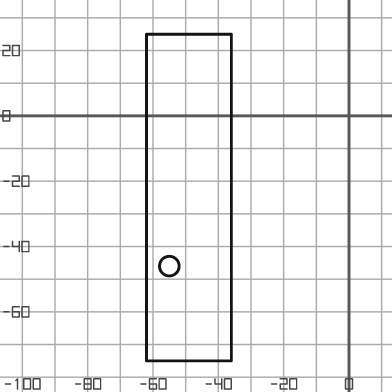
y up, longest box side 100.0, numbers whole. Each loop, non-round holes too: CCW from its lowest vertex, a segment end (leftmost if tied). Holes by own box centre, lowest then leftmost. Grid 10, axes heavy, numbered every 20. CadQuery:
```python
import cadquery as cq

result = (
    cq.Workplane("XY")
    .moveTo(-62.0, -75.0)
    .lineTo(-36.0, -75.0)
    .lineTo(-36.0, 25.0)
    .lineTo(-62.0, 25.0)
    .close()
    .moveTo(-55.0, -46.0)
    .circle(3.0)
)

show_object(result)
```